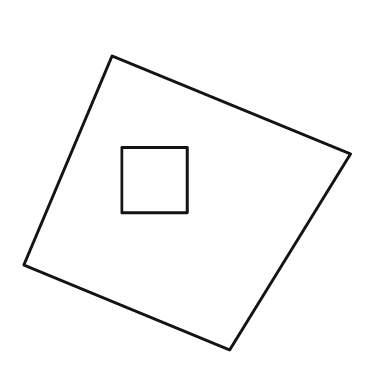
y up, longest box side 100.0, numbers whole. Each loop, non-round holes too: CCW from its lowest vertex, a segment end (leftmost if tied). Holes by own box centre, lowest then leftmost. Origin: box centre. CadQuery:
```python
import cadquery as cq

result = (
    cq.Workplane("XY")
    .moveTo(13.0, -45.0)
    .lineTo(50.0, 15.0)
    .lineTo(-23.0, 45.0)
    .lineTo(-50.0, -19.0)
    .close()
    .moveTo(-20.0, -3.0)
    .lineTo(0.0, -3.0)
    .lineTo(0.0, 17.0)
    .lineTo(-20.0, 17.0)
    .close()
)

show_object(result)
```